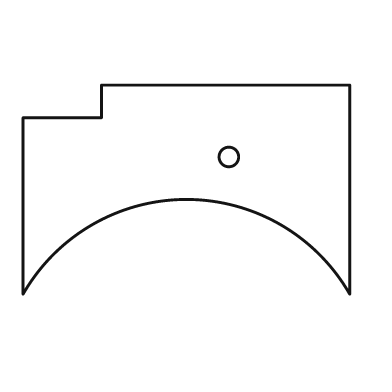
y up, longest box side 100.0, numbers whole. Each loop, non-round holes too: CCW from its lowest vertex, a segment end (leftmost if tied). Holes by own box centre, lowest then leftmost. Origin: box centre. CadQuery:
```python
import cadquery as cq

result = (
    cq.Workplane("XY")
    .moveTo(-50.0, -32.0)
    .threePointArc((0.0, -3.0), (50.0, -32.0))
    .lineTo(50.0, 32.0)
    .lineTo(-26.0, 32.0)
    .lineTo(-26.0, 22.0)
    .lineTo(-50.0, 22.0)
    .close()
    .moveTo(13.0, 10.0)
    .circle(3.0)
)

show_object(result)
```